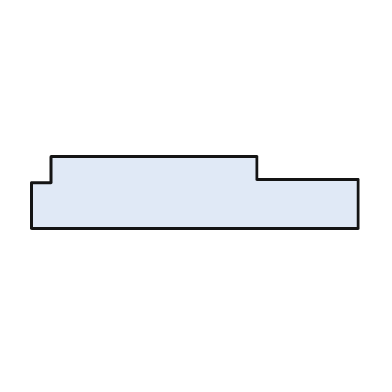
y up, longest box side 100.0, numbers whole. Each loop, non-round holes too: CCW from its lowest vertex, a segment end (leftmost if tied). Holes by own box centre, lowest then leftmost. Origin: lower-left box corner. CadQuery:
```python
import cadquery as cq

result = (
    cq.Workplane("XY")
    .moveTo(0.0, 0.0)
    .lineTo(100.0, 0.0)
    .lineTo(100.0, 15.0)
    .lineTo(69.0, 15.0)
    .lineTo(69.0, 22.0)
    .lineTo(6.0, 22.0)
    .lineTo(6.0, 14.0)
    .lineTo(0.0, 14.0)
    .close()
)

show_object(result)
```